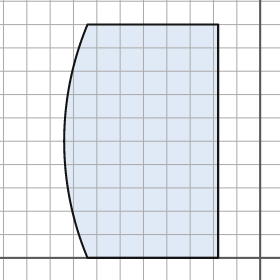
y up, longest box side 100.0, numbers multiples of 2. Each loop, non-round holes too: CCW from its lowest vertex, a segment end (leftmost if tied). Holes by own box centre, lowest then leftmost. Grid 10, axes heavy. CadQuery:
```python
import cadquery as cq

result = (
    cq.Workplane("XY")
    .moveTo(-74.0, 0.0)
    .lineTo(-18.0, 0.0)
    .lineTo(-18.0, 100.0)
    .lineTo(-74.0, 100.0)
    .threePointArc((-84.0, 50.0), (-74.0, 0.0))
    .close()
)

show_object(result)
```